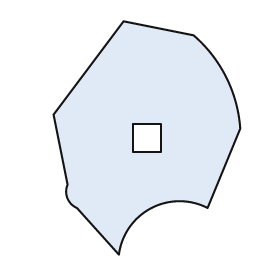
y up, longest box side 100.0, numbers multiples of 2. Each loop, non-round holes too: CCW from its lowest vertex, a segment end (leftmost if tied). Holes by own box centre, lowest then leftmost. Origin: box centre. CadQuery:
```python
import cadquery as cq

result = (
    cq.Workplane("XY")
    .moveTo(-12.0, -50.0)
    .threePointArc((2.0, -30.0), (26.0, -30.0))
    .lineTo(40.0, 4.0)
    .threePointArc((34.0, 26.0), (20.0, 44.0))
    .lineTo(-10.0, 50.0)
    .lineTo(-40.0, 10.0)
    .lineTo(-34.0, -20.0)
    .threePointArc((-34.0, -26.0), (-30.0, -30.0))
    .close()
    .moveTo(-6.0, -6.0)
    .lineTo(6.0, -6.0)
    .lineTo(6.0, 6.0)
    .lineTo(-6.0, 6.0)
    .close()
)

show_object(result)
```